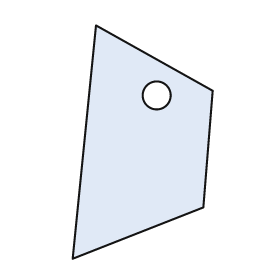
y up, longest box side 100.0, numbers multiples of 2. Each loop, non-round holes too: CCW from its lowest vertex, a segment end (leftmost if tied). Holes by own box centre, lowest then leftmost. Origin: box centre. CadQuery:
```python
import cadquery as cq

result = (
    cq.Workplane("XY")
    .moveTo(-30.0, -50.0)
    .lineTo(26.0, -28.0)
    .lineTo(30.0, 22.0)
    .lineTo(-20.0, 50.0)
    .close()
    .moveTo(6.0, 20.0)
    .circle(6.0)
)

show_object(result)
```